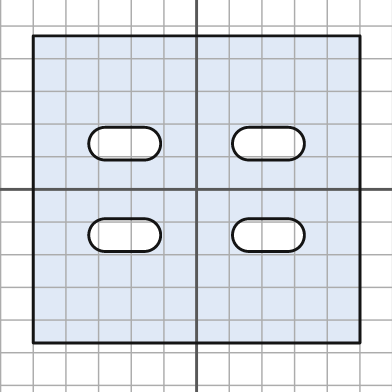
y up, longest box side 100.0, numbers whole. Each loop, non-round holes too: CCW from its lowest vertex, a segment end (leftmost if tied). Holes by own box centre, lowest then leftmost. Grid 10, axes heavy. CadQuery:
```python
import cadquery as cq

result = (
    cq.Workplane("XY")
    .moveTo(-50.0, -47.0)
    .lineTo(50.0, -47.0)
    .lineTo(50.0, 47.0)
    .lineTo(-50.0, 47.0)
    .close()
    .moveTo(-28.0, -19.0)
    .lineTo(-16.0, -19.0)
    .threePointArc((-11.0, -14.0), (-16.0, -9.0))
    .lineTo(-28.0, -9.0)
    .threePointArc((-33.0, -14.0), (-28.0, -19.0))
    .close()
    .moveTo(16.0, -19.0)
    .lineTo(28.0, -19.0)
    .threePointArc((33.0, -14.0), (28.0, -9.0))
    .lineTo(16.0, -9.0)
    .threePointArc((11.0, -14.0), (16.0, -19.0))
    .close()
    .moveTo(-28.0, 9.0)
    .lineTo(-16.0, 9.0)
    .threePointArc((-11.0, 14.0), (-16.0, 19.0))
    .lineTo(-28.0, 19.0)
    .threePointArc((-33.0, 14.0), (-28.0, 9.0))
    .close()
    .moveTo(16.0, 9.0)
    .lineTo(28.0, 9.0)
    .threePointArc((33.0, 14.0), (28.0, 19.0))
    .lineTo(16.0, 19.0)
    .threePointArc((11.0, 14.0), (16.0, 9.0))
    .close()
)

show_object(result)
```